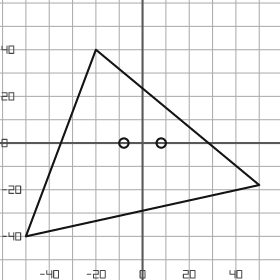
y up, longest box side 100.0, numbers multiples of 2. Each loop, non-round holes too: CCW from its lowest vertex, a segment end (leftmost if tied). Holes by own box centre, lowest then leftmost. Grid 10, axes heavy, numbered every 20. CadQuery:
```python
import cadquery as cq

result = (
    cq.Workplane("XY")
    .moveTo(-50.0, -40.0)
    .lineTo(50.0, -18.0)
    .lineTo(-20.0, 40.0)
    .close()
    .moveTo(-8.0, 0.0)
    .circle(2.0)
    .moveTo(8.0, 0.0)
    .circle(2.0)
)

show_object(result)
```